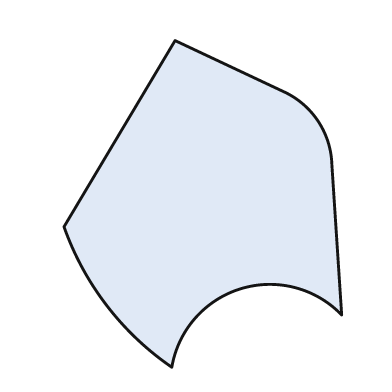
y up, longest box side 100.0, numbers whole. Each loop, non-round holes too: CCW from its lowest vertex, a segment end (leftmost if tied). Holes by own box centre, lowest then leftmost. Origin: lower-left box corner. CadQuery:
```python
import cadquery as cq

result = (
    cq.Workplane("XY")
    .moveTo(33.0, 0.0)
    .threePointArc((54.0, 24.0), (85.0, 16.0))
    .lineTo(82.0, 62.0)
    .threePointArc((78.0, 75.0), (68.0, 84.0))
    .lineTo(34.0, 100.0)
    .lineTo(0.0, 43.0)
    .threePointArc((13.0, 19.0), (33.0, 0.0))
    .close()
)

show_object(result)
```